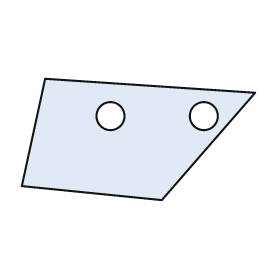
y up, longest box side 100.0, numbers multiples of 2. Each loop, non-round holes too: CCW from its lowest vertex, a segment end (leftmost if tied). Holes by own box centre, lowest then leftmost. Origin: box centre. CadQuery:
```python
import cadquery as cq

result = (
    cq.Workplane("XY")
    .moveTo(10.0, -26.0)
    .lineTo(50.0, 20.0)
    .lineTo(-40.0, 26.0)
    .lineTo(-50.0, -20.0)
    .close()
    .moveTo(-12.0, 10.0)
    .circle(6.0)
    .moveTo(28.0, 10.0)
    .circle(6.0)
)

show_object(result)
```